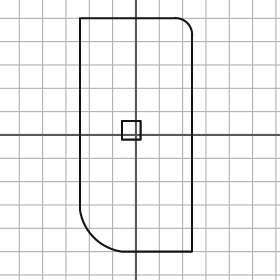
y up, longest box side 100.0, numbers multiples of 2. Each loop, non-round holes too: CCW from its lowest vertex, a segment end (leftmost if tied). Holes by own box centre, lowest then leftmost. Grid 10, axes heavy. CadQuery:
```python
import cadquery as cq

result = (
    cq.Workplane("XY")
    .moveTo(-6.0, -50.0)
    .lineTo(24.0, -50.0)
    .lineTo(24.0, 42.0)
    .threePointArc((22.0, 48.0), (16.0, 50.0))
    .lineTo(-24.0, 50.0)
    .lineTo(-24.0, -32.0)
    .threePointArc((-18.0, -44.0), (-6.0, -50.0))
    .close()
    .moveTo(-6.0, -2.0)
    .lineTo(2.0, -2.0)
    .lineTo(2.0, 6.0)
    .lineTo(-6.0, 6.0)
    .close()
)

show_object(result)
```